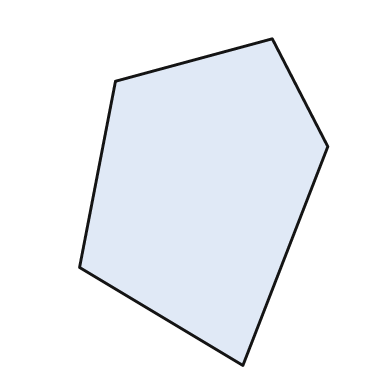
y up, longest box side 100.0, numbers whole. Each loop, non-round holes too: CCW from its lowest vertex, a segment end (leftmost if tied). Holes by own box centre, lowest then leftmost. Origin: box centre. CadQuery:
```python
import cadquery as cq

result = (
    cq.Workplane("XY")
    .moveTo(12.0, -50.0)
    .lineTo(38.0, 17.0)
    .lineTo(21.0, 50.0)
    .lineTo(-27.0, 37.0)
    .lineTo(-38.0, -20.0)
    .close()
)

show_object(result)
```